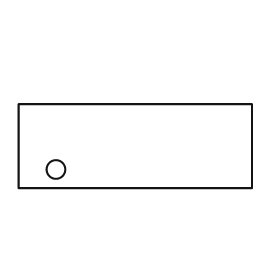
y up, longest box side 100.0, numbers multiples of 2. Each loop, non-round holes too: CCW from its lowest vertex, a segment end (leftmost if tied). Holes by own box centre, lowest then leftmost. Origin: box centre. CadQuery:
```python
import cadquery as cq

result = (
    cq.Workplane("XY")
    .moveTo(-50.0, -18.0)
    .lineTo(50.0, -18.0)
    .lineTo(50.0, 18.0)
    .lineTo(-50.0, 18.0)
    .close()
    .moveTo(-34.0, -10.0)
    .circle(4.0)
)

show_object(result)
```